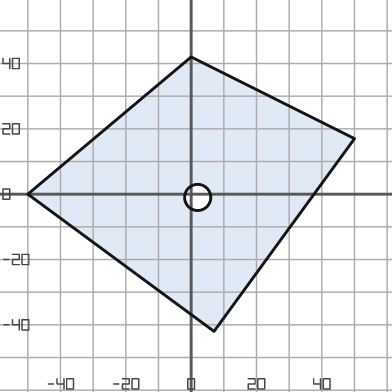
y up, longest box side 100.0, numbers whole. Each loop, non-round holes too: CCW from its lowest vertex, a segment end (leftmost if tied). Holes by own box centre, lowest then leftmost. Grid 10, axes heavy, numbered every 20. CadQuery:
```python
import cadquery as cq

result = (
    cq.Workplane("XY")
    .moveTo(7.0, -42.0)
    .lineTo(50.0, 17.0)
    .lineTo(0.0, 42.0)
    .lineTo(-50.0, 0.0)
    .close()
    .moveTo(2.0, -1.0)
    .circle(4.0)
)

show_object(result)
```